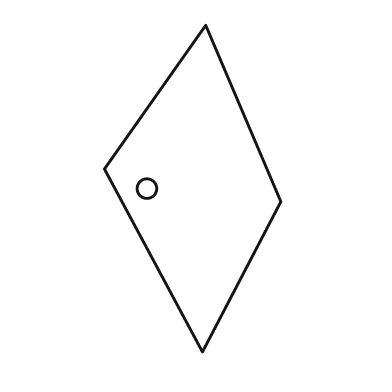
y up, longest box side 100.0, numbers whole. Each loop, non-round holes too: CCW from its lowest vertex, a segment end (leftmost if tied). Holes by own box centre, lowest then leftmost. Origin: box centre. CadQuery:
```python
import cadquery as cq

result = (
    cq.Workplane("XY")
    .moveTo(3.0, -50.0)
    .lineTo(27.0, -4.0)
    .lineTo(4.0, 50.0)
    .lineTo(-27.0, 6.0)
    .close()
    .moveTo(-14.0, 0.0)
    .circle(3.0)
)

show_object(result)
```